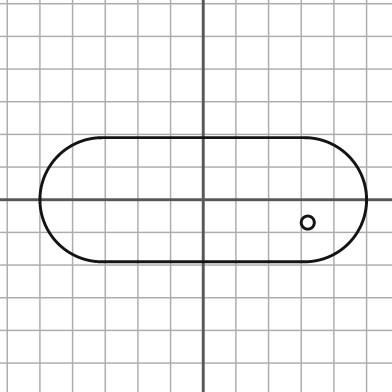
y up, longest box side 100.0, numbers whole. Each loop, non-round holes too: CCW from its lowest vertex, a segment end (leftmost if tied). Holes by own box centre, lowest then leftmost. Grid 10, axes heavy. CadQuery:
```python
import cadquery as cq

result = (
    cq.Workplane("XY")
    .moveTo(-31.0, -19.0)
    .lineTo(31.0, -19.0)
    .threePointArc((50.0, 0.0), (31.0, 19.0))
    .lineTo(-31.0, 19.0)
    .threePointArc((-50.0, 0.0), (-31.0, -19.0))
    .close()
    .moveTo(32.0, -7.0)
    .circle(2.0)
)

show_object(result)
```